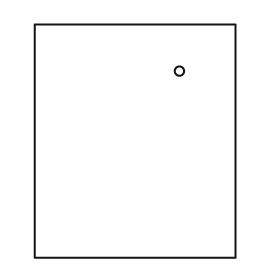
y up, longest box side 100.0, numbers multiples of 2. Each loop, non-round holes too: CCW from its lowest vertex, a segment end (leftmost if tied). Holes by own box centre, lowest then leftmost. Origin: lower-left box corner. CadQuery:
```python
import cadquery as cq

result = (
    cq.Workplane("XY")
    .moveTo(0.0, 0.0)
    .lineTo(86.0, 0.0)
    .lineTo(86.0, 100.0)
    .lineTo(0.0, 100.0)
    .close()
    .moveTo(62.0, 80.0)
    .circle(2.0)
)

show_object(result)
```